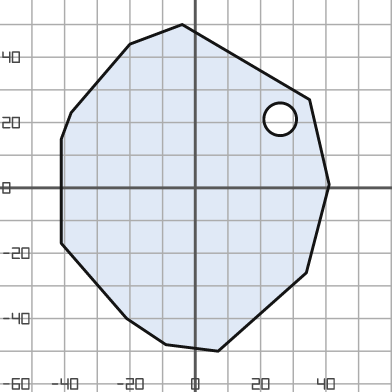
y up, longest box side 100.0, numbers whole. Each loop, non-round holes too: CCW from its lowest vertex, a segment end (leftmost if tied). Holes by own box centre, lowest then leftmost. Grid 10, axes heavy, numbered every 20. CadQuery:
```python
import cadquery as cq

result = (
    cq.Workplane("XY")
    .moveTo(7.0, -50.0)
    .lineTo(34.0, -26.0)
    .lineTo(41.0, 1.0)
    .lineTo(35.0, 27.0)
    .lineTo(-4.0, 50.0)
    .lineTo(-20.0, 44.0)
    .lineTo(-38.0, 23.0)
    .lineTo(-41.0, 15.0)
    .lineTo(-41.0, -17.0)
    .lineTo(-21.0, -40.0)
    .lineTo(-9.0, -48.0)
    .close()
    .moveTo(26.0, 21.0)
    .circle(5.0)
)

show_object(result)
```